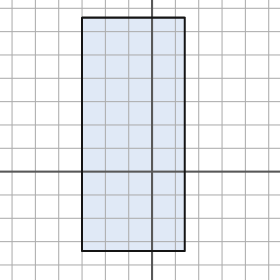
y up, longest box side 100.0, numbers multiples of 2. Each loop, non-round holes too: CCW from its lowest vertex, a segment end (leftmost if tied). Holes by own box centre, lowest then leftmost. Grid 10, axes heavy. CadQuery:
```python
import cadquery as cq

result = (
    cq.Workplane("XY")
    .moveTo(-30.0, -34.0)
    .lineTo(14.0, -34.0)
    .lineTo(14.0, 66.0)
    .lineTo(-30.0, 66.0)
    .close()
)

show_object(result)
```